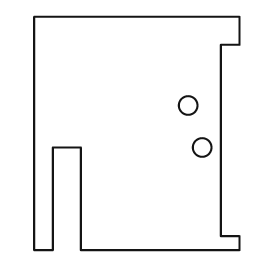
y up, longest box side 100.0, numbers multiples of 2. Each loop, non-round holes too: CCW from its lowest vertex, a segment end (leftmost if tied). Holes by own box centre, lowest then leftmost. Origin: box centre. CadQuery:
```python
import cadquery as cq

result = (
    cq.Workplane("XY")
    .moveTo(-44.0, -50.0)
    .lineTo(-36.0, -50.0)
    .lineTo(-36.0, -6.0)
    .lineTo(-24.0, -6.0)
    .lineTo(-24.0, -50.0)
    .lineTo(44.0, -50.0)
    .lineTo(44.0, -44.0)
    .lineTo(36.0, -44.0)
    .lineTo(36.0, 38.0)
    .lineTo(44.0, 38.0)
    .lineTo(44.0, 50.0)
    .lineTo(-44.0, 50.0)
    .close()
    .moveTo(28.0, -6.0)
    .circle(4.0)
    .moveTo(22.0, 12.0)
    .circle(4.0)
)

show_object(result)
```